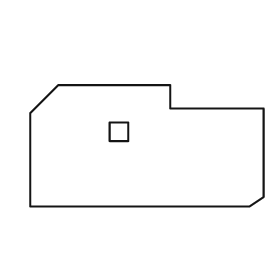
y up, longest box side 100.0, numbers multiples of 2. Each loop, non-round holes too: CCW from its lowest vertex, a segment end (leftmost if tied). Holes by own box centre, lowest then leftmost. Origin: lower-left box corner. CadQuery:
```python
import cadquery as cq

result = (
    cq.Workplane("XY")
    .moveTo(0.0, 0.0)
    .lineTo(94.0, 0.0)
    .lineTo(100.0, 4.0)
    .lineTo(100.0, 42.0)
    .lineTo(60.0, 42.0)
    .lineTo(60.0, 52.0)
    .lineTo(12.0, 52.0)
    .lineTo(0.0, 40.0)
    .close()
    .moveTo(34.0, 28.0)
    .lineTo(42.0, 28.0)
    .lineTo(42.0, 36.0)
    .lineTo(34.0, 36.0)
    .close()
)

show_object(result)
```